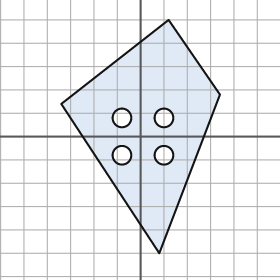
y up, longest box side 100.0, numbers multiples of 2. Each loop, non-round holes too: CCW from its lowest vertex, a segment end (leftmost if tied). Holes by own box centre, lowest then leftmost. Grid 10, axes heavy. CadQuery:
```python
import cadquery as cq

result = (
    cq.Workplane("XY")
    .moveTo(8.0, -50.0)
    .lineTo(34.0, 18.0)
    .lineTo(12.0, 50.0)
    .lineTo(-34.0, 14.0)
    .close()
    .moveTo(-8.0, -8.0)
    .circle(4.0)
    .moveTo(10.0, -8.0)
    .circle(4.0)
    .moveTo(-8.0, 8.0)
    .circle(4.0)
    .moveTo(10.0, 8.0)
    .circle(4.0)
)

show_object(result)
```